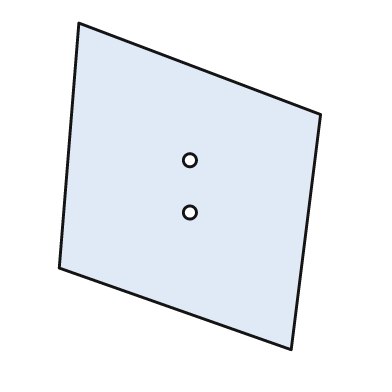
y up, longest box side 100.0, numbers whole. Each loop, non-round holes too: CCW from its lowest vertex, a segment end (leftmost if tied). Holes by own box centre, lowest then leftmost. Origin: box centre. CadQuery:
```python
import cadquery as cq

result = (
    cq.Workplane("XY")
    .moveTo(31.0, -50.0)
    .lineTo(40.0, 22.0)
    .lineTo(-34.0, 50.0)
    .lineTo(-40.0, -25.0)
    .close()
    .moveTo(0.0, -8.0)
    .circle(2.0)
    .moveTo(0.0, 8.0)
    .circle(2.0)
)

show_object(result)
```